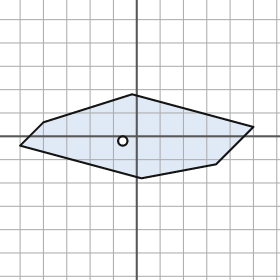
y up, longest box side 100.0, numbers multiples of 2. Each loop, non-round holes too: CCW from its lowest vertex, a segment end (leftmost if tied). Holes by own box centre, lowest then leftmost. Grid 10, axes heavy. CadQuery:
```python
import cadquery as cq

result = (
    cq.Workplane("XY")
    .moveTo(2.0, -18.0)
    .lineTo(34.0, -12.0)
    .lineTo(50.0, 4.0)
    .lineTo(-2.0, 18.0)
    .lineTo(-40.0, 6.0)
    .lineTo(-50.0, -4.0)
    .close()
    .moveTo(-6.0, -2.0)
    .circle(2.0)
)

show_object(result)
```